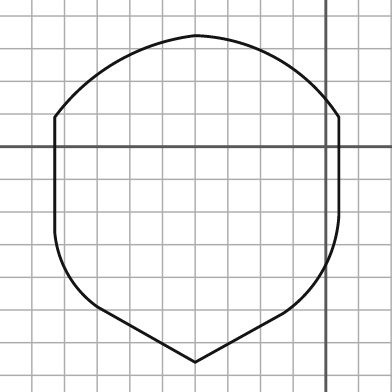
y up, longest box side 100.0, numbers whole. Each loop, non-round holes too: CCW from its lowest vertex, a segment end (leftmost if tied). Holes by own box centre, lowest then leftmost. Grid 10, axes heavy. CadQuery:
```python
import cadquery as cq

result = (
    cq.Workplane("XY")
    .moveTo(-40.0, -66.0)
    .lineTo(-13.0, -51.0)
    .threePointArc((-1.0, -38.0), (4.0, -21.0))
    .lineTo(4.0, 9.0)
    .threePointArc((-15.0, 27.0), (-40.0, 34.0))
    .threePointArc((-64.0, 26.0), (-83.0, 9.0))
    .lineTo(-83.0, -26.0)
    .threePointArc((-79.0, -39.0), (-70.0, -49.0))
    .close()
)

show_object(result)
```